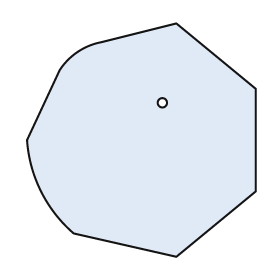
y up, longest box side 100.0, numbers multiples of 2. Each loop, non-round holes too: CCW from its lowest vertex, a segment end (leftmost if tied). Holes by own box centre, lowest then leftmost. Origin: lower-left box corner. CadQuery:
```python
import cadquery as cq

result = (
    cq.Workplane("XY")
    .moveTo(64.0, 0.0)
    .lineTo(98.0, 28.0)
    .lineTo(98.0, 72.0)
    .lineTo(64.0, 100.0)
    .lineTo(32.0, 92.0)
    .threePointArc((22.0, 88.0), (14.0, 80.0))
    .lineTo(0.0, 50.0)
    .threePointArc((6.0, 28.0), (20.0, 10.0))
    .close()
    .moveTo(58.0, 66.0)
    .circle(2.0)
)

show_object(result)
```